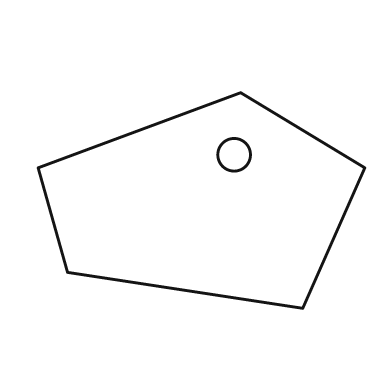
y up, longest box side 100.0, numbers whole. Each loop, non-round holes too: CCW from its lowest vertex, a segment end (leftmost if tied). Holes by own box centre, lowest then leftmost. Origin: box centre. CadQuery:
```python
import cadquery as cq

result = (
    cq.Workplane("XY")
    .moveTo(31.0, -33.0)
    .lineTo(50.0, 10.0)
    .lineTo(12.0, 33.0)
    .lineTo(-50.0, 10.0)
    .lineTo(-41.0, -22.0)
    .close()
    .moveTo(10.0, 14.0)
    .circle(5.0)
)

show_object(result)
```